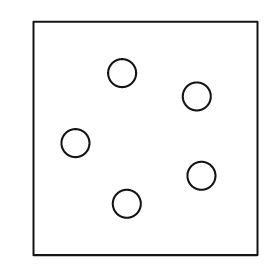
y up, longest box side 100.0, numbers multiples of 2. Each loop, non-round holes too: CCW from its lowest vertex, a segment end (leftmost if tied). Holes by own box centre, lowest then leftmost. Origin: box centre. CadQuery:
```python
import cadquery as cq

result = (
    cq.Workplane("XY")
    .moveTo(-48.0, -50.0)
    .lineTo(48.0, -50.0)
    .lineTo(48.0, 50.0)
    .lineTo(-48.0, 50.0)
    .close()
    .moveTo(-8.0, -28.0)
    .circle(6.0)
    .moveTo(24.0, -16.0)
    .circle(6.0)
    .moveTo(-30.0, -2.0)
    .circle(6.0)
    .moveTo(22.0, 18.0)
    .circle(6.0)
    .moveTo(-10.0, 28.0)
    .circle(6.0)
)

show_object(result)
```